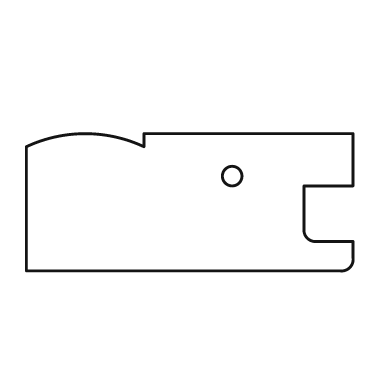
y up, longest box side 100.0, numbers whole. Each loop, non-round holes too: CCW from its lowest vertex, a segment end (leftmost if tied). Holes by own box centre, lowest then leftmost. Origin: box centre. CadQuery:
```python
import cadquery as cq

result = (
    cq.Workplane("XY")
    .moveTo(-50.0, -21.0)
    .lineTo(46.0, -21.0)
    .threePointArc((49.0, -20.0), (50.0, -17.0))
    .lineTo(50.0, -12.0)
    .lineTo(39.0, -12.0)
    .threePointArc((36.0, -11.0), (35.0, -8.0))
    .lineTo(35.0, 5.0)
    .lineTo(50.0, 5.0)
    .lineTo(50.0, 21.0)
    .lineTo(-14.0, 21.0)
    .lineTo(-14.0, 17.0)
    .threePointArc((-32.0, 21.0), (-50.0, 17.0))
    .close()
    .moveTo(13.0, 8.0)
    .circle(3.0)
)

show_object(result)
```